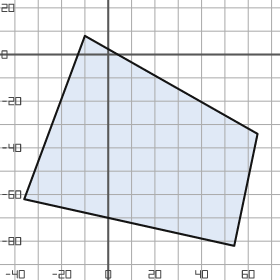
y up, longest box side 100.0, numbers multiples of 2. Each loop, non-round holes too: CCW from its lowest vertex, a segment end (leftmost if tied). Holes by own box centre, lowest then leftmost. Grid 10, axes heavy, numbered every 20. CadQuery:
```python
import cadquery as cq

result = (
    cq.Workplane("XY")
    .moveTo(54.0, -82.0)
    .lineTo(64.0, -34.0)
    .lineTo(-10.0, 8.0)
    .lineTo(-36.0, -62.0)
    .close()
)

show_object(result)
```